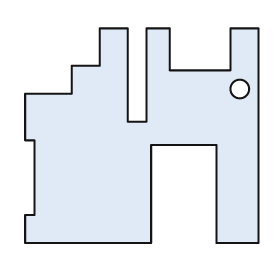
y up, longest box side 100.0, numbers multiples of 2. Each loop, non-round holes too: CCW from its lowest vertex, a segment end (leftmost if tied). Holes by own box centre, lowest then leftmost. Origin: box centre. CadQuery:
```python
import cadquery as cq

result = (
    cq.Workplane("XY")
    .moveTo(-50.0, -46.0)
    .lineTo(4.0, -46.0)
    .lineTo(4.0, -4.0)
    .lineTo(32.0, -4.0)
    .lineTo(32.0, -46.0)
    .lineTo(50.0, -46.0)
    .lineTo(50.0, 46.0)
    .lineTo(38.0, 46.0)
    .lineTo(38.0, 28.0)
    .lineTo(12.0, 28.0)
    .lineTo(12.0, 46.0)
    .lineTo(2.0, 46.0)
    .lineTo(2.0, 6.0)
    .lineTo(-6.0, 6.0)
    .lineTo(-6.0, 46.0)
    .lineTo(-18.0, 46.0)
    .lineTo(-18.0, 30.0)
    .lineTo(-30.0, 30.0)
    .lineTo(-30.0, 18.0)
    .lineTo(-50.0, 18.0)
    .lineTo(-50.0, -2.0)
    .lineTo(-46.0, -2.0)
    .lineTo(-46.0, -34.0)
    .lineTo(-50.0, -34.0)
    .close()
    .moveTo(42.0, 20.0)
    .circle(4.0)
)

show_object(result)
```